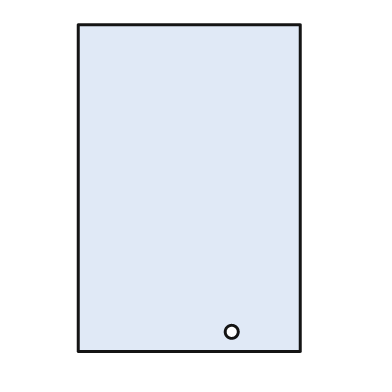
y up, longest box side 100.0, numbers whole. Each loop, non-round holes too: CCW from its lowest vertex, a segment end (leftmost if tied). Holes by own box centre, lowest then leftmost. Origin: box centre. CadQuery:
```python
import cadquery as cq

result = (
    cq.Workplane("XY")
    .moveTo(-34.0, -50.0)
    .lineTo(34.0, -50.0)
    .lineTo(34.0, 50.0)
    .lineTo(-34.0, 50.0)
    .close()
    .moveTo(13.0, -44.0)
    .circle(2.0)
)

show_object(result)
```